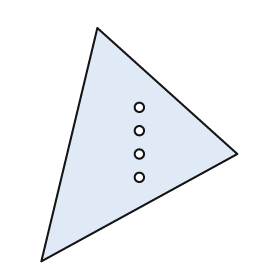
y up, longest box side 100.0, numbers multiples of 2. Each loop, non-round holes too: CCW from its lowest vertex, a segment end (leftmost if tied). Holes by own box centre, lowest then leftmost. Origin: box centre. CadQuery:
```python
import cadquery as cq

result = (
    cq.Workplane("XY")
    .moveTo(-42.0, -50.0)
    .lineTo(42.0, -4.0)
    .lineTo(-18.0, 50.0)
    .close()
    .moveTo(0.0, -14.0)
    .circle(2.0)
    .moveTo(0.0, -4.0)
    .circle(2.0)
    .moveTo(0.0, 6.0)
    .circle(2.0)
    .moveTo(0.0, 16.0)
    .circle(2.0)
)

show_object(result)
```